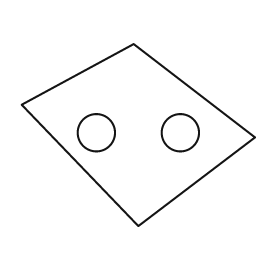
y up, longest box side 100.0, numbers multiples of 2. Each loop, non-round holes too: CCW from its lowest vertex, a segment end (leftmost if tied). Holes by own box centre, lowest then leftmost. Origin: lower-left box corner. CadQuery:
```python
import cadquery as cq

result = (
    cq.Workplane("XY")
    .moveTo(50.0, 0.0)
    .lineTo(100.0, 38.0)
    .lineTo(48.0, 78.0)
    .lineTo(0.0, 52.0)
    .close()
    .moveTo(32.0, 40.0)
    .circle(8.0)
    .moveTo(68.0, 40.0)
    .circle(8.0)
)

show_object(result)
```